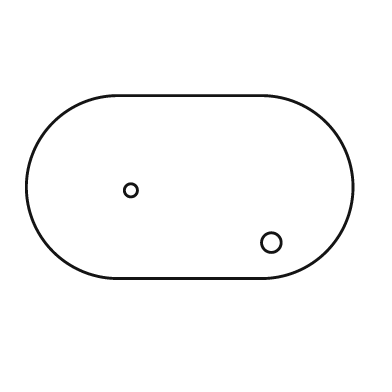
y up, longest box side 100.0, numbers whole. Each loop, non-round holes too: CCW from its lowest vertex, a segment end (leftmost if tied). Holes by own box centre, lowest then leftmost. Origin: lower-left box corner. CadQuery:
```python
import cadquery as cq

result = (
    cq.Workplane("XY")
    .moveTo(28.0, 0.0)
    .lineTo(72.0, 0.0)
    .threePointArc((100.0, 28.0), (72.0, 56.0))
    .lineTo(28.0, 56.0)
    .threePointArc((0.0, 28.0), (28.0, 0.0))
    .close()
    .moveTo(75.0, 11.0)
    .circle(3.0)
    .moveTo(32.0, 27.0)
    .circle(2.0)
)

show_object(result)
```